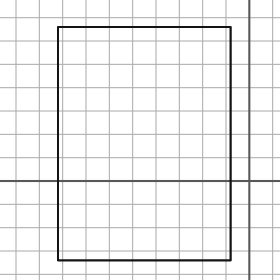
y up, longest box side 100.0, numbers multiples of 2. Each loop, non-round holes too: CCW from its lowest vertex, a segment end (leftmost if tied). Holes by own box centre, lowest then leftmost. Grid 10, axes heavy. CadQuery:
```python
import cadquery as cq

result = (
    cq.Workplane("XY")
    .moveTo(-82.0, -34.0)
    .lineTo(-8.0, -34.0)
    .lineTo(-8.0, 66.0)
    .lineTo(-82.0, 66.0)
    .close()
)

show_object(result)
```